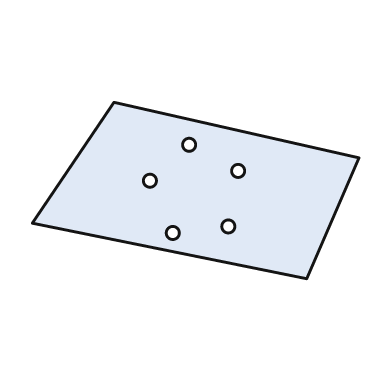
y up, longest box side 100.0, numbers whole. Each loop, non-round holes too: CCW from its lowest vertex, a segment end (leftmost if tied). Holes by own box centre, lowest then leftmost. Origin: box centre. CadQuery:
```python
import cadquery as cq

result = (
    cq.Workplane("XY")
    .moveTo(34.0, -27.0)
    .lineTo(50.0, 10.0)
    .lineTo(-25.0, 27.0)
    .lineTo(-50.0, -10.0)
    .close()
    .moveTo(-7.0, -13.0)
    .circle(2.0)
    .moveTo(10.0, -11.0)
    .circle(2.0)
    .moveTo(-14.0, 3.0)
    .circle(2.0)
    .moveTo(13.0, 6.0)
    .circle(2.0)
    .moveTo(-2.0, 14.0)
    .circle(2.0)
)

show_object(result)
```